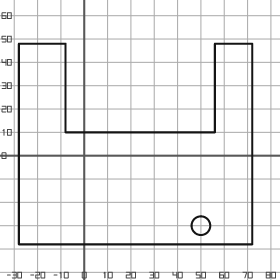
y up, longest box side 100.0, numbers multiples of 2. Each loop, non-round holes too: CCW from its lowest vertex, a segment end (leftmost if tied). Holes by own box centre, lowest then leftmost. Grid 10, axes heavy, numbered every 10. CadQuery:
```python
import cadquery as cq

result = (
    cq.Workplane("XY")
    .moveTo(-28.0, -38.0)
    .lineTo(72.0, -38.0)
    .lineTo(72.0, 48.0)
    .lineTo(56.0, 48.0)
    .lineTo(56.0, 10.0)
    .lineTo(-8.0, 10.0)
    .lineTo(-8.0, 48.0)
    .lineTo(-28.0, 48.0)
    .close()
    .moveTo(50.0, -30.0)
    .circle(4.0)
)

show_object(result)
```